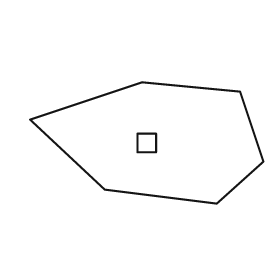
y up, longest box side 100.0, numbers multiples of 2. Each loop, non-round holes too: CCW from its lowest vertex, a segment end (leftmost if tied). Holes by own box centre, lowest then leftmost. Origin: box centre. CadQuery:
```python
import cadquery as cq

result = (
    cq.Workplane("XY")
    .moveTo(30.0, -26.0)
    .lineTo(50.0, -8.0)
    .lineTo(40.0, 22.0)
    .lineTo(-2.0, 26.0)
    .lineTo(-50.0, 10.0)
    .lineTo(-18.0, -20.0)
    .close()
    .moveTo(-4.0, -4.0)
    .lineTo(4.0, -4.0)
    .lineTo(4.0, 4.0)
    .lineTo(-4.0, 4.0)
    .close()
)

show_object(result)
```